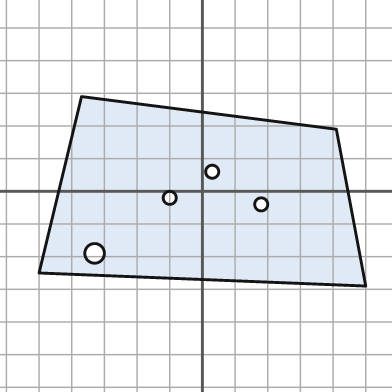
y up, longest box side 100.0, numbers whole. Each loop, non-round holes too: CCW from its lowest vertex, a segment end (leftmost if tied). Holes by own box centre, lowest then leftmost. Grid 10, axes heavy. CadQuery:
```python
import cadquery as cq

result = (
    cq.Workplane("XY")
    .moveTo(50.0, -29.0)
    .lineTo(41.0, 19.0)
    .lineTo(-37.0, 29.0)
    .lineTo(-50.0, -25.0)
    .close()
    .moveTo(-33.0, -19.0)
    .circle(3.0)
    .moveTo(18.0, -4.0)
    .circle(2.0)
    .moveTo(-10.0, -2.0)
    .circle(2.0)
    .moveTo(3.0, 6.0)
    .circle(2.0)
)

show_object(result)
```